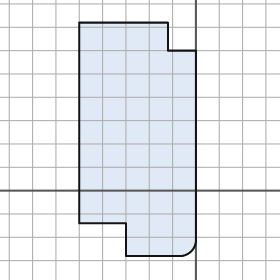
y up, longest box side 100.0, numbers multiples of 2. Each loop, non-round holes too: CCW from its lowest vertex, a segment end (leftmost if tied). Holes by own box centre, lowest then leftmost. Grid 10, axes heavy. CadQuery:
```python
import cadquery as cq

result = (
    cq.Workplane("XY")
    .moveTo(-30.0, -28.0)
    .lineTo(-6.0, -28.0)
    .threePointArc((-2.0, -26.0), (0.0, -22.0))
    .lineTo(0.0, 60.0)
    .lineTo(-12.0, 60.0)
    .lineTo(-12.0, 72.0)
    .lineTo(-50.0, 72.0)
    .lineTo(-50.0, -14.0)
    .lineTo(-30.0, -14.0)
    .close()
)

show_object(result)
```